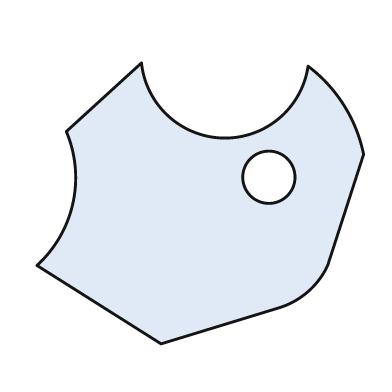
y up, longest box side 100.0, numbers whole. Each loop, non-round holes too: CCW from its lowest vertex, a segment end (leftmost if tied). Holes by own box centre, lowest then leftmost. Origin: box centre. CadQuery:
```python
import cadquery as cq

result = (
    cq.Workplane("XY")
    .moveTo(-12.0, -43.0)
    .lineTo(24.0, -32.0)
    .threePointArc((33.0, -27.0), (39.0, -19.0))
    .lineTo(50.0, 15.0)
    .threePointArc((44.0, 30.0), (33.0, 42.0))
    .threePointArc((7.0, 20.0), (-18.0, 43.0))
    .lineTo(-41.0, 22.0)
    .threePointArc((-39.0, 0.0), (-50.0, -19.0))
    .close()
    .moveTo(21.0, 8.0)
    .circle(8.0)
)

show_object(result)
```